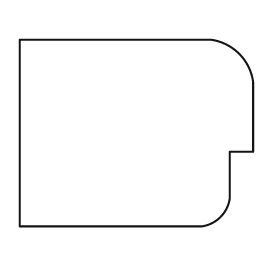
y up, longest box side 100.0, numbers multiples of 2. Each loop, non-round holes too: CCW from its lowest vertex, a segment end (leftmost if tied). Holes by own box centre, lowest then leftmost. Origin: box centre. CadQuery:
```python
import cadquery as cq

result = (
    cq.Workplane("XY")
    .moveTo(-50.0, -40.0)
    .lineTo(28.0, -40.0)
    .threePointArc((36.0, -36.0), (40.0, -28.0))
    .lineTo(40.0, -8.0)
    .lineTo(50.0, -8.0)
    .lineTo(50.0, 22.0)
    .threePointArc((44.0, 34.0), (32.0, 40.0))
    .lineTo(-50.0, 40.0)
    .close()
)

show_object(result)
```